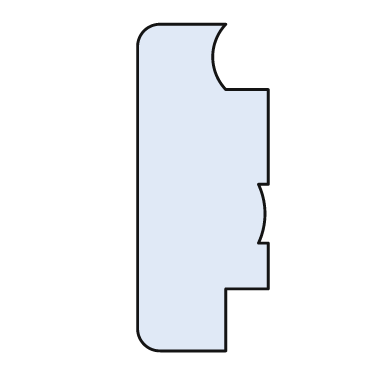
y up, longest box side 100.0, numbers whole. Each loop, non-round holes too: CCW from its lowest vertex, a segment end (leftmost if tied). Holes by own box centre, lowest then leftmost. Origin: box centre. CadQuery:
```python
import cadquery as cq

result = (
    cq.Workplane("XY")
    .moveTo(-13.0, -50.0)
    .lineTo(7.0, -50.0)
    .lineTo(7.0, -31.0)
    .lineTo(20.0, -31.0)
    .lineTo(20.0, -17.0)
    .lineTo(17.0, -17.0)
    .threePointArc((19.0, -8.0), (17.0, 1.0))
    .lineTo(20.0, 1.0)
    .lineTo(20.0, 30.0)
    .lineTo(7.0, 30.0)
    .threePointArc((3.0, 40.0), (7.0, 50.0))
    .lineTo(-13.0, 50.0)
    .threePointArc((-18.0, 48.0), (-20.0, 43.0))
    .lineTo(-20.0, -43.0)
    .threePointArc((-18.0, -48.0), (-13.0, -50.0))
    .close()
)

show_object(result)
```